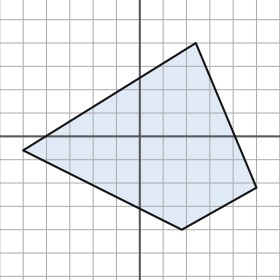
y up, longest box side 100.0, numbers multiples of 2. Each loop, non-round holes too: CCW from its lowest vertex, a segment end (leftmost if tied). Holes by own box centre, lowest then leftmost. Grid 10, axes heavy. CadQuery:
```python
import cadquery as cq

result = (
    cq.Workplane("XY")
    .moveTo(18.0, -40.0)
    .lineTo(50.0, -22.0)
    .lineTo(24.0, 40.0)
    .lineTo(-50.0, -6.0)
    .close()
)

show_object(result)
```